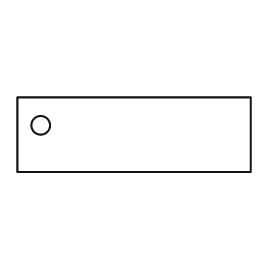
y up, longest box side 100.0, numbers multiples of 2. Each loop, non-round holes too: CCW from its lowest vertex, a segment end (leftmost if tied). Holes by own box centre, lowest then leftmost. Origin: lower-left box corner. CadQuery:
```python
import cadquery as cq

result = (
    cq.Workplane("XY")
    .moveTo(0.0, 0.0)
    .lineTo(100.0, 0.0)
    .lineTo(100.0, 32.0)
    .lineTo(0.0, 32.0)
    .close()
    .moveTo(10.0, 20.0)
    .circle(4.0)
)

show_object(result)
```